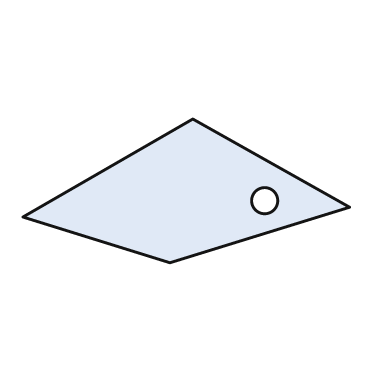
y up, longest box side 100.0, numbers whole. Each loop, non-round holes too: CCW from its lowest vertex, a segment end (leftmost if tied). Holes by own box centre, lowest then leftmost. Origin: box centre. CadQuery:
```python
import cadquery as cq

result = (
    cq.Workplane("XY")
    .moveTo(-5.0, -22.0)
    .lineTo(50.0, -5.0)
    .lineTo(2.0, 22.0)
    .lineTo(-50.0, -8.0)
    .close()
    .moveTo(24.0, -3.0)
    .circle(4.0)
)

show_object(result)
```